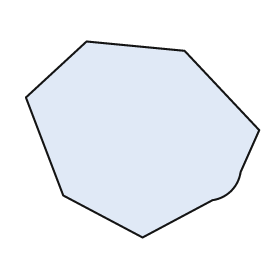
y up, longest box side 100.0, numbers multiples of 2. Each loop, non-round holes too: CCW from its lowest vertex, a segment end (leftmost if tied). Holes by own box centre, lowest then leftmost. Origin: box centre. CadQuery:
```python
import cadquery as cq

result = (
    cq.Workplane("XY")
    .moveTo(0.0, -42.0)
    .lineTo(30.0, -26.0)
    .threePointArc((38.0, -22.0), (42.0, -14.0))
    .lineTo(50.0, 4.0)
    .lineTo(18.0, 38.0)
    .lineTo(-24.0, 42.0)
    .lineTo(-50.0, 18.0)
    .lineTo(-34.0, -24.0)
    .close()
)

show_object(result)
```